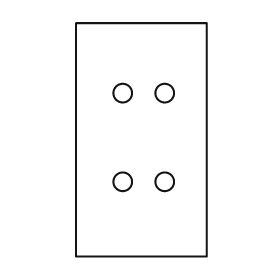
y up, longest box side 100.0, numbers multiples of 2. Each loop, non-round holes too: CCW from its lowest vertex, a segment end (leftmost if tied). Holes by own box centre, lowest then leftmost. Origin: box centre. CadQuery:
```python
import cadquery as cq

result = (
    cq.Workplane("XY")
    .moveTo(-28.0, -50.0)
    .lineTo(28.0, -50.0)
    .lineTo(28.0, 50.0)
    .lineTo(-28.0, 50.0)
    .close()
    .moveTo(-8.0, -18.0)
    .circle(4.0)
    .moveTo(10.0, -18.0)
    .circle(4.0)
    .moveTo(-8.0, 20.0)
    .circle(4.0)
    .moveTo(10.0, 20.0)
    .circle(4.0)
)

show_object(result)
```